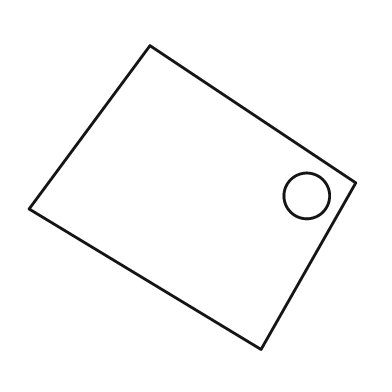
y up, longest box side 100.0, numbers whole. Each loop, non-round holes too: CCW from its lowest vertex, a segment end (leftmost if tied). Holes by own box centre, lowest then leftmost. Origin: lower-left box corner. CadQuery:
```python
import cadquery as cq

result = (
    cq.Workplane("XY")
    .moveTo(71.0, 0.0)
    .lineTo(100.0, 51.0)
    .lineTo(37.0, 93.0)
    .lineTo(0.0, 43.0)
    .close()
    .moveTo(85.0, 47.0)
    .circle(7.0)
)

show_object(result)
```